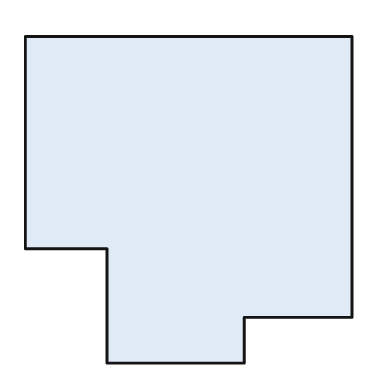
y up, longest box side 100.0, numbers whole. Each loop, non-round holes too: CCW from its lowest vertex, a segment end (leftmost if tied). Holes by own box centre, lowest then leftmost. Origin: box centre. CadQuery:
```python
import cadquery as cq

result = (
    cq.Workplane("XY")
    .moveTo(-25.0, -50.0)
    .lineTo(17.0, -50.0)
    .lineTo(17.0, -36.0)
    .lineTo(50.0, -36.0)
    .lineTo(50.0, 50.0)
    .lineTo(-50.0, 50.0)
    .lineTo(-50.0, -15.0)
    .lineTo(-25.0, -15.0)
    .close()
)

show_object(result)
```